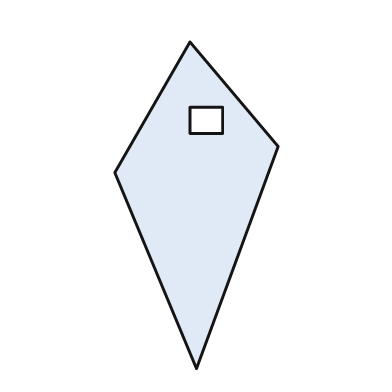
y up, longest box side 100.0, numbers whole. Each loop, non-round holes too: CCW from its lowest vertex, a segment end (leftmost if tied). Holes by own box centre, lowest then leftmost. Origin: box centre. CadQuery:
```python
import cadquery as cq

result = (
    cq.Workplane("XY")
    .moveTo(0.0, -50.0)
    .lineTo(25.0, 18.0)
    .lineTo(-2.0, 50.0)
    .lineTo(-25.0, 10.0)
    .close()
    .moveTo(-2.0, 22.0)
    .lineTo(8.0, 22.0)
    .lineTo(8.0, 30.0)
    .lineTo(-2.0, 30.0)
    .close()
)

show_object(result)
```